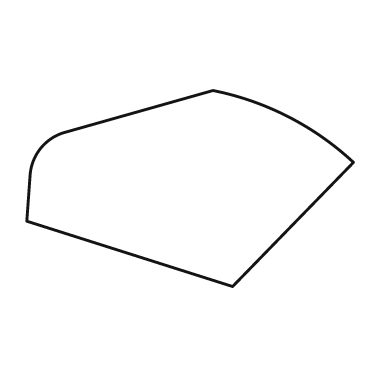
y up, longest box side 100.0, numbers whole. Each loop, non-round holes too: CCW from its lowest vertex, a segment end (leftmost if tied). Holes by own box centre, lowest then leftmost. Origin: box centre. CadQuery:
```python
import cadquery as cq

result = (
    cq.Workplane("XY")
    .moveTo(13.0, -30.0)
    .lineTo(50.0, 8.0)
    .threePointArc((30.0, 22.0), (7.0, 30.0))
    .lineTo(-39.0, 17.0)
    .threePointArc((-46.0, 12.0), (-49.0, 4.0))
    .lineTo(-50.0, -10.0)
    .close()
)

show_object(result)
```